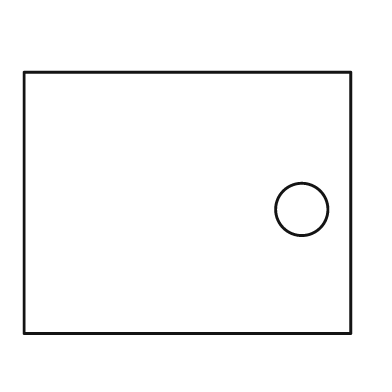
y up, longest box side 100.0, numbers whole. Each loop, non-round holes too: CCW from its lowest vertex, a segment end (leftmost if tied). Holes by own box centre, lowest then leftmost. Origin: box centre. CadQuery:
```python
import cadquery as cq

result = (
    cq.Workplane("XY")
    .moveTo(-50.0, -40.0)
    .lineTo(50.0, -40.0)
    .lineTo(50.0, 40.0)
    .lineTo(-50.0, 40.0)
    .close()
    .moveTo(35.0, -2.0)
    .circle(8.0)
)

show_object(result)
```